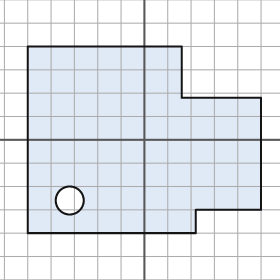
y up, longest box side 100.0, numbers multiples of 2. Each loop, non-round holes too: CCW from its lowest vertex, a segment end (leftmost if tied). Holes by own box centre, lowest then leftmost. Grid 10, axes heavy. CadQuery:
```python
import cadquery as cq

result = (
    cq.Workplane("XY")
    .moveTo(-50.0, -40.0)
    .lineTo(22.0, -40.0)
    .lineTo(22.0, -30.0)
    .lineTo(50.0, -30.0)
    .lineTo(50.0, 18.0)
    .lineTo(16.0, 18.0)
    .lineTo(16.0, 40.0)
    .lineTo(-50.0, 40.0)
    .close()
    .moveTo(-32.0, -26.0)
    .circle(6.0)
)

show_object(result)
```